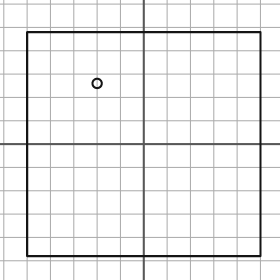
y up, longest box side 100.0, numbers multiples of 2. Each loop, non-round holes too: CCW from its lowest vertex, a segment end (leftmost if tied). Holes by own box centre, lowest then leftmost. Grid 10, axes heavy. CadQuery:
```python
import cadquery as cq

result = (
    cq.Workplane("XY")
    .moveTo(-50.0, -48.0)
    .lineTo(50.0, -48.0)
    .lineTo(50.0, 48.0)
    .lineTo(-50.0, 48.0)
    .close()
    .moveTo(-20.0, 26.0)
    .circle(2.0)
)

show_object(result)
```